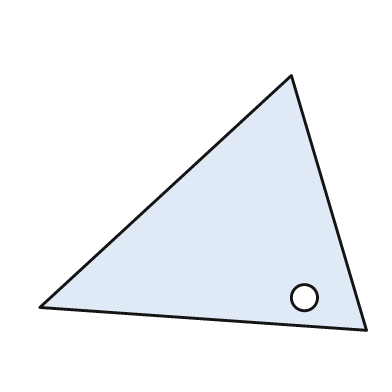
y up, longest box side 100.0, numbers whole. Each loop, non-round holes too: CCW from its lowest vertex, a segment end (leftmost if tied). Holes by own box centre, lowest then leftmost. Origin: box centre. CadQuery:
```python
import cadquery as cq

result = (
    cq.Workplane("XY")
    .moveTo(50.0, -39.0)
    .lineTo(27.0, 39.0)
    .lineTo(-50.0, -32.0)
    .close()
    .moveTo(31.0, -29.0)
    .circle(4.0)
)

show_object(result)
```